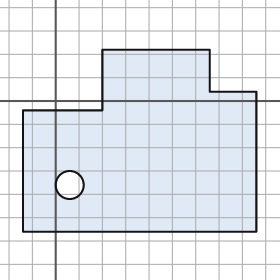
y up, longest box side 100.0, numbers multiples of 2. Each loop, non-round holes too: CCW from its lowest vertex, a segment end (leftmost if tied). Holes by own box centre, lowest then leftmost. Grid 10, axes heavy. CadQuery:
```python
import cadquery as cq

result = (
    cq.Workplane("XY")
    .moveTo(-14.0, -56.0)
    .lineTo(86.0, -56.0)
    .lineTo(86.0, 4.0)
    .lineTo(66.0, 4.0)
    .lineTo(66.0, 22.0)
    .lineTo(20.0, 22.0)
    .lineTo(20.0, -4.0)
    .lineTo(-14.0, -4.0)
    .close()
    .moveTo(6.0, -36.0)
    .circle(6.0)
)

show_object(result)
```